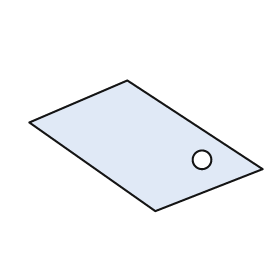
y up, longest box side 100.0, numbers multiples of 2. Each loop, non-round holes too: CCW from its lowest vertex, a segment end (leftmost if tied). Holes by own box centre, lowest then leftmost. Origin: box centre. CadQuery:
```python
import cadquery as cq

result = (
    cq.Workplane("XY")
    .moveTo(4.0, -28.0)
    .lineTo(50.0, -10.0)
    .lineTo(-8.0, 28.0)
    .lineTo(-50.0, 10.0)
    .close()
    .moveTo(24.0, -6.0)
    .circle(4.0)
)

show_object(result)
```